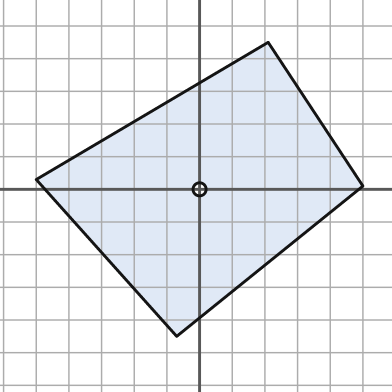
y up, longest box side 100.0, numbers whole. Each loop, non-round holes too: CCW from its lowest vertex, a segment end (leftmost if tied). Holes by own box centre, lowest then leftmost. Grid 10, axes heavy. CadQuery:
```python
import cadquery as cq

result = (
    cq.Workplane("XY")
    .moveTo(-7.0, -45.0)
    .lineTo(50.0, 1.0)
    .lineTo(21.0, 45.0)
    .lineTo(-50.0, 3.0)
    .close()
    .moveTo(0.0, 0.0)
    .circle(2.0)
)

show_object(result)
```